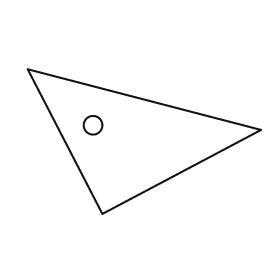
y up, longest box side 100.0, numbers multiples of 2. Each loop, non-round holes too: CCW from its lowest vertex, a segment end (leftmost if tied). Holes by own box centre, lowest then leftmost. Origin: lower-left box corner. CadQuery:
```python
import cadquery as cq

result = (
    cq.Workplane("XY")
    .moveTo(32.0, 0.0)
    .lineTo(100.0, 36.0)
    .lineTo(0.0, 62.0)
    .close()
    .moveTo(28.0, 38.0)
    .circle(4.0)
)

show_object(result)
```